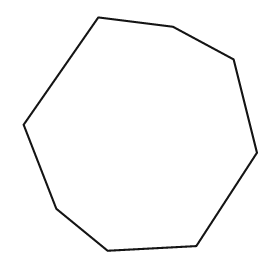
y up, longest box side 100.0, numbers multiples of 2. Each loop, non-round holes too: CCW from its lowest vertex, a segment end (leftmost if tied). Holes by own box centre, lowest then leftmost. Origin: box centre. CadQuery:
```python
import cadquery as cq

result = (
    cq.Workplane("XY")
    .moveTo(-14.0, -50.0)
    .lineTo(24.0, -48.0)
    .lineTo(50.0, -8.0)
    .lineTo(40.0, 32.0)
    .lineTo(14.0, 46.0)
    .lineTo(-18.0, 50.0)
    .lineTo(-50.0, 4.0)
    .lineTo(-36.0, -32.0)
    .close()
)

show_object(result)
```